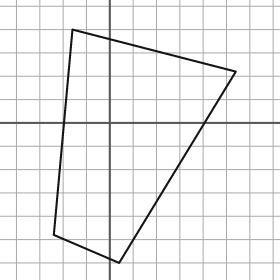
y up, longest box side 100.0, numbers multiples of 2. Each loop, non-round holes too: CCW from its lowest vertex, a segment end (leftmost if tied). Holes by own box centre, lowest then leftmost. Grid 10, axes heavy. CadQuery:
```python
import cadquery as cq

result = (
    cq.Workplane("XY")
    .moveTo(4.0, -60.0)
    .lineTo(54.0, 22.0)
    .lineTo(-16.0, 40.0)
    .lineTo(-24.0, -48.0)
    .close()
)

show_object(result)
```